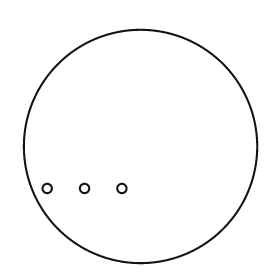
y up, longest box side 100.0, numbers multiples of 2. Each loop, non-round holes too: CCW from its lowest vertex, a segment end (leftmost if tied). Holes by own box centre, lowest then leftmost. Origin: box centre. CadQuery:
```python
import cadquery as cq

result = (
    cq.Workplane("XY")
    .moveTo(0.0, 0.0)
    .circle(50.0)
    .moveTo(-40.0, -18.0)
    .circle(2.0)
    .moveTo(-24.0, -18.0)
    .circle(2.0)
    .moveTo(-8.0, -18.0)
    .circle(2.0)
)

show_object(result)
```